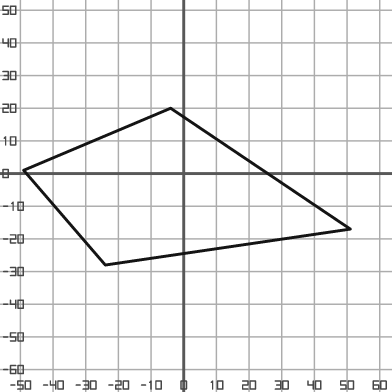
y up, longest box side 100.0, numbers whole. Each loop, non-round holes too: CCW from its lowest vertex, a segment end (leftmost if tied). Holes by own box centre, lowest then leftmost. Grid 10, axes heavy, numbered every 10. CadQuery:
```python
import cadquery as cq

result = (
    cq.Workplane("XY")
    .moveTo(-24.0, -28.0)
    .lineTo(51.0, -17.0)
    .lineTo(-4.0, 20.0)
    .lineTo(-49.0, 1.0)
    .close()
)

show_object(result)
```